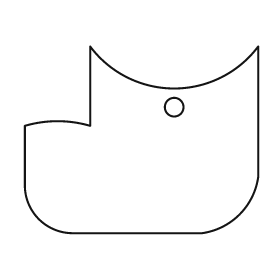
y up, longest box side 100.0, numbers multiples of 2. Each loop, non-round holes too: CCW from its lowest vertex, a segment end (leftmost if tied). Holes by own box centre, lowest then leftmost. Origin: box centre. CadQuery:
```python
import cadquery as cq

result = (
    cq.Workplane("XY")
    .moveTo(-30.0, -40.0)
    .lineTo(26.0, -40.0)
    .threePointArc((42.0, -32.0), (50.0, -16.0))
    .lineTo(50.0, 40.0)
    .threePointArc((14.0, 22.0), (-22.0, 40.0))
    .lineTo(-22.0, 6.0)
    .threePointArc((-36.0, 8.0), (-50.0, 6.0))
    .lineTo(-50.0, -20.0)
    .threePointArc((-44.0, -34.0), (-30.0, -40.0))
    .close()
    .moveTo(14.0, 14.0)
    .circle(4.0)
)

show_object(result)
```